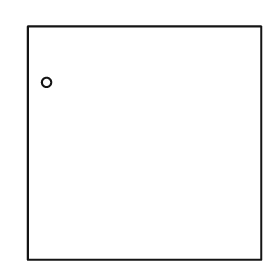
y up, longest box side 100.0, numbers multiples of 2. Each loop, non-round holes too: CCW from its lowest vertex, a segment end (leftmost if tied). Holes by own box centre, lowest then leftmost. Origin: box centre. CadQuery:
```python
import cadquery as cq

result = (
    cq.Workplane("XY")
    .moveTo(-50.0, -50.0)
    .lineTo(50.0, -50.0)
    .lineTo(50.0, 50.0)
    .lineTo(-50.0, 50.0)
    .close()
    .moveTo(-42.0, 26.0)
    .circle(2.0)
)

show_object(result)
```